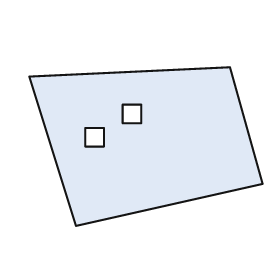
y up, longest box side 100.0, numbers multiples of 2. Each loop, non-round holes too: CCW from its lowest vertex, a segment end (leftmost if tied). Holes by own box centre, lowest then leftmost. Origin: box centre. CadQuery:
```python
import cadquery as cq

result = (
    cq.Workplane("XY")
    .moveTo(-30.0, -34.0)
    .lineTo(50.0, -16.0)
    .lineTo(36.0, 34.0)
    .lineTo(-50.0, 30.0)
    .close()
    .moveTo(-26.0, 0.0)
    .lineTo(-18.0, 0.0)
    .lineTo(-18.0, 8.0)
    .lineTo(-26.0, 8.0)
    .close()
    .moveTo(-10.0, 10.0)
    .lineTo(-2.0, 10.0)
    .lineTo(-2.0, 18.0)
    .lineTo(-10.0, 18.0)
    .close()
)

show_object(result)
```